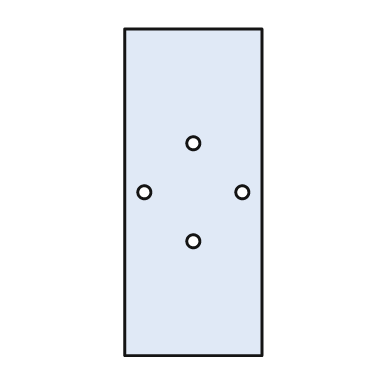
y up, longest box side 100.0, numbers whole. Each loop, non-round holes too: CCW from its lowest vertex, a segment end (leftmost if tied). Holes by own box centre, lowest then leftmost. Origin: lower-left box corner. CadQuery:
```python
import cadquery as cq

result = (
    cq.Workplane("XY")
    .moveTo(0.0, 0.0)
    .lineTo(42.0, 0.0)
    .lineTo(42.0, 100.0)
    .lineTo(0.0, 100.0)
    .close()
    .moveTo(21.0, 35.0)
    .circle(2.0)
    .moveTo(6.0, 50.0)
    .circle(2.0)
    .moveTo(36.0, 50.0)
    .circle(2.0)
    .moveTo(21.0, 65.0)
    .circle(2.0)
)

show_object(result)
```